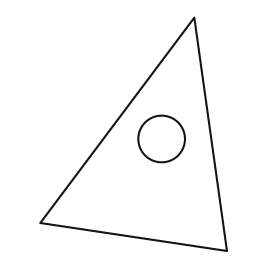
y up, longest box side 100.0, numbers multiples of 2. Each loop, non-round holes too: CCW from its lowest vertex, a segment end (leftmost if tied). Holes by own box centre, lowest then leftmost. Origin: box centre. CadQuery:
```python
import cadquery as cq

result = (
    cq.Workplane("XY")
    .moveTo(40.0, -50.0)
    .lineTo(26.0, 50.0)
    .lineTo(-40.0, -38.0)
    .close()
    .moveTo(12.0, -2.0)
    .circle(10.0)
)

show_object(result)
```